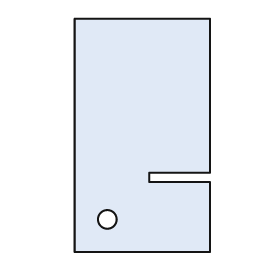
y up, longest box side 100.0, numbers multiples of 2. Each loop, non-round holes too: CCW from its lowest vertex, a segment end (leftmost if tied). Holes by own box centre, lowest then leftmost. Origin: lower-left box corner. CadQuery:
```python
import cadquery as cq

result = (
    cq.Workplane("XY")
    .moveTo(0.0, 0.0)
    .lineTo(58.0, 0.0)
    .lineTo(58.0, 30.0)
    .lineTo(32.0, 30.0)
    .lineTo(32.0, 34.0)
    .lineTo(58.0, 34.0)
    .lineTo(58.0, 100.0)
    .lineTo(0.0, 100.0)
    .close()
    .moveTo(14.0, 14.0)
    .circle(4.0)
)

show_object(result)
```